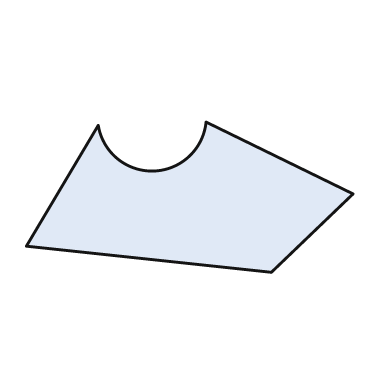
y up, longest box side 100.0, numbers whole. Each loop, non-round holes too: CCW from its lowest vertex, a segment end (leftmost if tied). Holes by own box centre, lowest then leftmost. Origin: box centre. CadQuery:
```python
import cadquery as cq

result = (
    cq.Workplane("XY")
    .moveTo(25.0, -23.0)
    .lineTo(50.0, 1.0)
    .lineTo(5.0, 23.0)
    .threePointArc((-11.0, 8.0), (-28.0, 22.0))
    .lineTo(-50.0, -15.0)
    .close()
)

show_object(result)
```